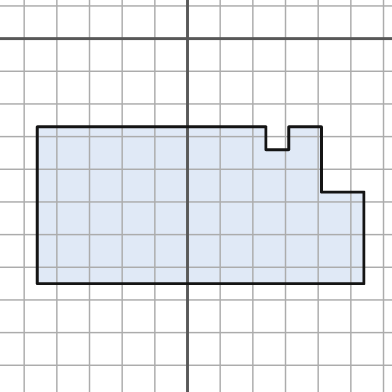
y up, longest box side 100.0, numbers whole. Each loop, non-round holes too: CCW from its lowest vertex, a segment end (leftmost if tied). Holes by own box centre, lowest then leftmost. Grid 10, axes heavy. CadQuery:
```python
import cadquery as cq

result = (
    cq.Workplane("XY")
    .moveTo(-46.0, -75.0)
    .lineTo(54.0, -75.0)
    .lineTo(54.0, -47.0)
    .lineTo(41.0, -47.0)
    .lineTo(41.0, -27.0)
    .lineTo(31.0, -27.0)
    .lineTo(31.0, -34.0)
    .lineTo(24.0, -34.0)
    .lineTo(24.0, -27.0)
    .lineTo(-46.0, -27.0)
    .close()
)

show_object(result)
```